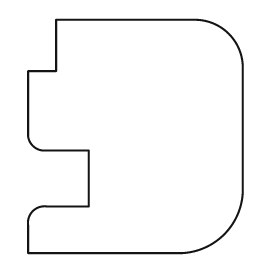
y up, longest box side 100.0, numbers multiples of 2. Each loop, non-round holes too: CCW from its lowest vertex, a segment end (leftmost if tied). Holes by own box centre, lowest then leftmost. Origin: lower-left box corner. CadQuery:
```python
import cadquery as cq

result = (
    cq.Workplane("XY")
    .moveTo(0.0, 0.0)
    .lineTo(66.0, 0.0)
    .threePointArc((84.0, 8.0), (92.0, 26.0))
    .lineTo(92.0, 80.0)
    .threePointArc((86.0, 94.0), (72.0, 100.0))
    .lineTo(12.0, 100.0)
    .lineTo(12.0, 78.0)
    .lineTo(0.0, 78.0)
    .lineTo(0.0, 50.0)
    .threePointArc((2.0, 46.0), (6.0, 44.0))
    .lineTo(26.0, 44.0)
    .lineTo(26.0, 20.0)
    .lineTo(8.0, 20.0)
    .threePointArc((2.0, 18.0), (0.0, 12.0))
    .close()
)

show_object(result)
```